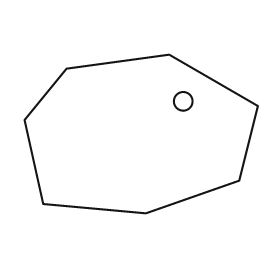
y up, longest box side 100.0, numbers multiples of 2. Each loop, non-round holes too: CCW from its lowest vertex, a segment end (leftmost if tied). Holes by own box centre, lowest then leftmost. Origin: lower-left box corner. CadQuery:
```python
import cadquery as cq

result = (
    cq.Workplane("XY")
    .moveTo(52.0, 0.0)
    .lineTo(92.0, 14.0)
    .lineTo(100.0, 46.0)
    .lineTo(62.0, 68.0)
    .lineTo(18.0, 62.0)
    .lineTo(0.0, 40.0)
    .lineTo(8.0, 4.0)
    .close()
    .moveTo(68.0, 48.0)
    .circle(4.0)
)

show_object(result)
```